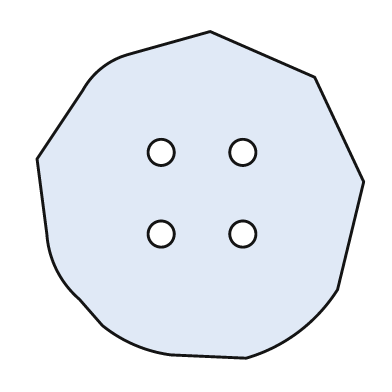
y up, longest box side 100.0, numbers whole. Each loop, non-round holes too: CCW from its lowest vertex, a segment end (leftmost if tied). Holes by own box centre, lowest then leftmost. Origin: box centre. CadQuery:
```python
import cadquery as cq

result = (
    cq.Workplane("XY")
    .moveTo(14.0, -50.0)
    .threePointArc((30.0, -42.0), (42.0, -29.0))
    .lineTo(50.0, 4.0)
    .lineTo(35.0, 36.0)
    .lineTo(3.0, 50.0)
    .lineTo(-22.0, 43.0)
    .threePointArc((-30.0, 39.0), (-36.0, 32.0))
    .lineTo(-50.0, 11.0)
    .lineTo(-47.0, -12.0)
    .threePointArc((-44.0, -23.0), (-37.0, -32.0))
    .lineTo(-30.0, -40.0)
    .threePointArc((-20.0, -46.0), (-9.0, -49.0))
    .close()
    .moveTo(-12.0, -12.0)
    .circle(4.0)
    .moveTo(13.0, -12.0)
    .circle(4.0)
    .moveTo(-12.0, 13.0)
    .circle(4.0)
    .moveTo(13.0, 13.0)
    .circle(4.0)
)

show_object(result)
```